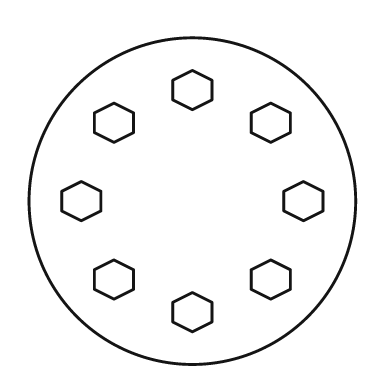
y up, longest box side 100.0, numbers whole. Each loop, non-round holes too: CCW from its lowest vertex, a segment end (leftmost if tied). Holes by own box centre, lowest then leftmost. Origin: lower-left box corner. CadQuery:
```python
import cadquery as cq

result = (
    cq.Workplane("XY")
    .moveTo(50.0, 50.0)
    .circle(50.0)
    .moveTo(50.0, 10.0)
    .lineTo(56.0, 13.0)
    .lineTo(56.0, 19.0)
    .lineTo(50.0, 22.0)
    .lineTo(44.0, 19.0)
    .lineTo(44.0, 13.0)
    .close()
    .moveTo(26.0, 20.0)
    .lineTo(32.0, 23.0)
    .lineTo(32.0, 29.0)
    .lineTo(26.0, 32.0)
    .lineTo(20.0, 29.0)
    .lineTo(20.0, 23.0)
    .close()
    .moveTo(74.0, 20.0)
    .lineTo(80.0, 23.0)
    .lineTo(80.0, 29.0)
    .lineTo(74.0, 32.0)
    .lineTo(68.0, 29.0)
    .lineTo(68.0, 23.0)
    .close()
    .moveTo(16.0, 44.0)
    .lineTo(22.0, 47.0)
    .lineTo(22.0, 53.0)
    .lineTo(16.0, 56.0)
    .lineTo(10.0, 53.0)
    .lineTo(10.0, 47.0)
    .close()
    .moveTo(84.0, 44.0)
    .lineTo(90.0, 47.0)
    .lineTo(90.0, 53.0)
    .lineTo(84.0, 56.0)
    .lineTo(78.0, 53.0)
    .lineTo(78.0, 47.0)
    .close()
    .moveTo(26.0, 68.0)
    .lineTo(32.0, 71.0)
    .lineTo(32.0, 77.0)
    .lineTo(26.0, 80.0)
    .lineTo(20.0, 77.0)
    .lineTo(20.0, 71.0)
    .close()
    .moveTo(74.0, 68.0)
    .lineTo(80.0, 71.0)
    .lineTo(80.0, 77.0)
    .lineTo(74.0, 80.0)
    .lineTo(68.0, 77.0)
    .lineTo(68.0, 71.0)
    .close()
    .moveTo(50.0, 78.0)
    .lineTo(56.0, 81.0)
    .lineTo(56.0, 87.0)
    .lineTo(50.0, 90.0)
    .lineTo(44.0, 87.0)
    .lineTo(44.0, 81.0)
    .close()
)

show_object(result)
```